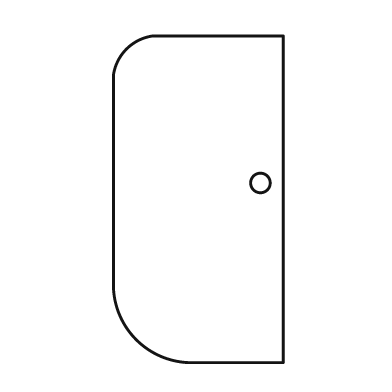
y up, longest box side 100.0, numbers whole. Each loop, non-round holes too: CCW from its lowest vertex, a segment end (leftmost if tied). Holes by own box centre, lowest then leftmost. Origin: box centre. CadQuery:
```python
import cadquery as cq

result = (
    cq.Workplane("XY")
    .moveTo(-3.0, -50.0)
    .lineTo(26.0, -50.0)
    .lineTo(26.0, 50.0)
    .lineTo(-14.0, 50.0)
    .threePointArc((-22.0, 46.0), (-26.0, 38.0))
    .lineTo(-26.0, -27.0)
    .threePointArc((-19.0, -43.0), (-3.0, -50.0))
    .close()
    .moveTo(19.0, 5.0)
    .circle(3.0)
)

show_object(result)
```